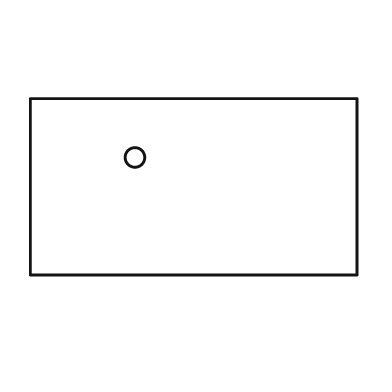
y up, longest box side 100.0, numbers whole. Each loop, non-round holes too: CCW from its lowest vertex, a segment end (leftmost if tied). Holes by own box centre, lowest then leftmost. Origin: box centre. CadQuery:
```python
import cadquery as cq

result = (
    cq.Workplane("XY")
    .moveTo(-50.0, -27.0)
    .lineTo(50.0, -27.0)
    .lineTo(50.0, 27.0)
    .lineTo(-50.0, 27.0)
    .close()
    .moveTo(-18.0, 9.0)
    .circle(3.0)
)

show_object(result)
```